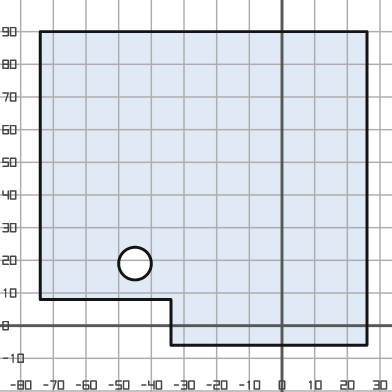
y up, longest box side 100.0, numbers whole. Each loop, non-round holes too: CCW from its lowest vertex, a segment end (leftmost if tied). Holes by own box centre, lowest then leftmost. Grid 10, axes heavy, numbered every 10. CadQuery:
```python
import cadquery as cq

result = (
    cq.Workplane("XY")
    .moveTo(-34.0, -6.0)
    .lineTo(26.0, -6.0)
    .lineTo(26.0, 90.0)
    .lineTo(-74.0, 90.0)
    .lineTo(-74.0, 8.0)
    .lineTo(-34.0, 8.0)
    .close()
    .moveTo(-45.0, 19.0)
    .circle(5.0)
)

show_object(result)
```